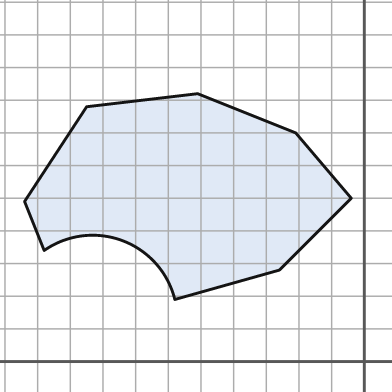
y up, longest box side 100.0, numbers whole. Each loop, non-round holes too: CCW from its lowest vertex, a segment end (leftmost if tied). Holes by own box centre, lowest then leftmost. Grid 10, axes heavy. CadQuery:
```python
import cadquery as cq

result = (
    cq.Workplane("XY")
    .moveTo(-58.0, 19.0)
    .lineTo(-26.0, 28.0)
    .lineTo(-4.0, 50.0)
    .lineTo(-21.0, 70.0)
    .lineTo(-51.0, 82.0)
    .lineTo(-85.0, 78.0)
    .lineTo(-104.0, 49.0)
    .lineTo(-98.0, 34.0)
    .threePointArc((-74.0, 37.0), (-58.0, 19.0))
    .close()
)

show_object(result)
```